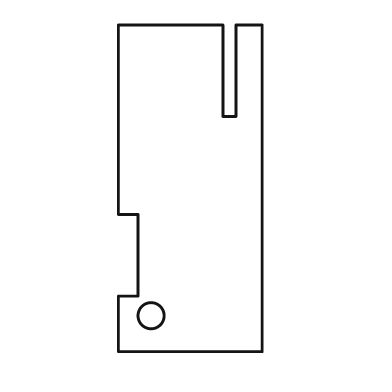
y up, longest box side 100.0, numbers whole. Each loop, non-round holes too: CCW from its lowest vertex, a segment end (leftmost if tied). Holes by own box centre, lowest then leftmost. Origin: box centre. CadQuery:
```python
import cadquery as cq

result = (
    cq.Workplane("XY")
    .moveTo(-22.0, -50.0)
    .lineTo(22.0, -50.0)
    .lineTo(22.0, 50.0)
    .lineTo(14.0, 50.0)
    .lineTo(14.0, 22.0)
    .lineTo(10.0, 22.0)
    .lineTo(10.0, 50.0)
    .lineTo(-22.0, 50.0)
    .lineTo(-22.0, -8.0)
    .lineTo(-16.0, -8.0)
    .lineTo(-16.0, -33.0)
    .lineTo(-22.0, -33.0)
    .close()
    .moveTo(-12.0, -39.0)
    .circle(4.0)
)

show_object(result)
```